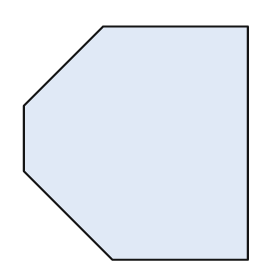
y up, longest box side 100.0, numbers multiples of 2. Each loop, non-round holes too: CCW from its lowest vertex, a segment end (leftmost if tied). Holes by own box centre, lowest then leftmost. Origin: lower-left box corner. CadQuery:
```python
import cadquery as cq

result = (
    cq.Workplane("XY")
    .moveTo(38.0, 0.0)
    .lineTo(96.0, 0.0)
    .lineTo(96.0, 100.0)
    .lineTo(34.0, 100.0)
    .lineTo(0.0, 66.0)
    .lineTo(0.0, 38.0)
    .close()
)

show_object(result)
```